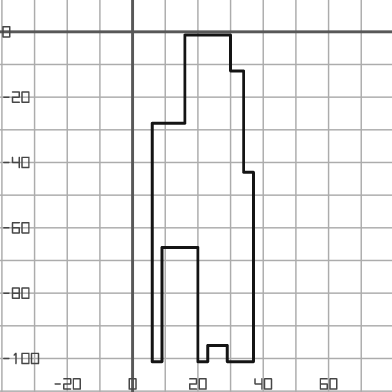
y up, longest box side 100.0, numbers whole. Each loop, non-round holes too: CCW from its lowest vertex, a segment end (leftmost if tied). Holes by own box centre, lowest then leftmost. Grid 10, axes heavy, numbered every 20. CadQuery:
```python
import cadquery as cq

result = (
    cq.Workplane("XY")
    .moveTo(6.0, -101.0)
    .lineTo(9.0, -101.0)
    .lineTo(9.0, -66.0)
    .lineTo(20.0, -66.0)
    .lineTo(20.0, -101.0)
    .lineTo(23.0, -101.0)
    .lineTo(23.0, -96.0)
    .lineTo(29.0, -96.0)
    .lineTo(29.0, -101.0)
    .lineTo(37.0, -101.0)
    .lineTo(37.0, -43.0)
    .lineTo(34.0, -43.0)
    .lineTo(34.0, -12.0)
    .lineTo(30.0, -12.0)
    .lineTo(30.0, -1.0)
    .lineTo(16.0, -1.0)
    .lineTo(16.0, -28.0)
    .lineTo(6.0, -28.0)
    .close()
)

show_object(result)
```